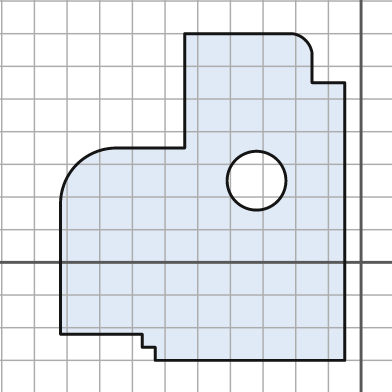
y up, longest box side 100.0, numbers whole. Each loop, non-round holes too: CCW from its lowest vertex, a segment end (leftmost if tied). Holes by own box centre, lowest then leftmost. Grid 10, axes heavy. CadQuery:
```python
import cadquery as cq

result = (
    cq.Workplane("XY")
    .moveTo(-63.0, -30.0)
    .lineTo(-5.0, -30.0)
    .lineTo(-5.0, 55.0)
    .lineTo(-15.0, 55.0)
    .lineTo(-15.0, 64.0)
    .threePointArc((-17.0, 68.0), (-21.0, 70.0))
    .lineTo(-54.0, 70.0)
    .lineTo(-54.0, 35.0)
    .lineTo(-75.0, 35.0)
    .threePointArc((-87.0, 30.0), (-92.0, 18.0))
    .lineTo(-92.0, -22.0)
    .lineTo(-67.0, -22.0)
    .lineTo(-67.0, -26.0)
    .lineTo(-63.0, -26.0)
    .close()
    .moveTo(-32.0, 25.0)
    .circle(9.0)
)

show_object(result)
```